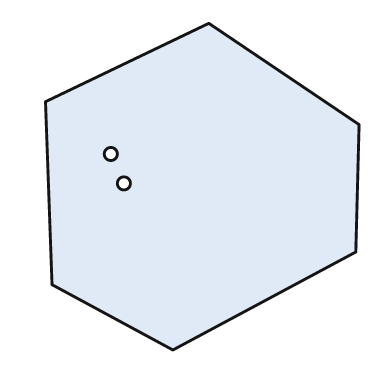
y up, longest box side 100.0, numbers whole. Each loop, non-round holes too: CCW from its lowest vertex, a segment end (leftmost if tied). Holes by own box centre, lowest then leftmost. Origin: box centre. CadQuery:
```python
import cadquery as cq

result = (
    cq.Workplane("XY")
    .moveTo(-9.0, -50.0)
    .lineTo(47.0, -20.0)
    .lineTo(48.0, 19.0)
    .lineTo(2.0, 50.0)
    .lineTo(-48.0, 26.0)
    .lineTo(-46.0, -30.0)
    .close()
    .moveTo(-24.0, 1.0)
    .circle(2.0)
    .moveTo(-28.0, 10.0)
    .circle(2.0)
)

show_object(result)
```